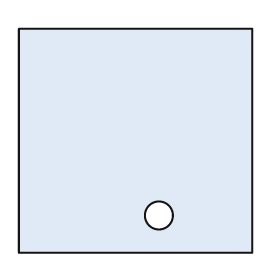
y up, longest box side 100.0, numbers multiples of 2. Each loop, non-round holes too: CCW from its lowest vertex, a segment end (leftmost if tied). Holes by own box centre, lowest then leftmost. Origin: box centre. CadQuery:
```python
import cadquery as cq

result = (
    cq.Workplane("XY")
    .moveTo(-50.0, -48.0)
    .lineTo(50.0, -48.0)
    .lineTo(50.0, 48.0)
    .lineTo(-50.0, 48.0)
    .close()
    .moveTo(10.0, -32.0)
    .circle(6.0)
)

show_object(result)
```